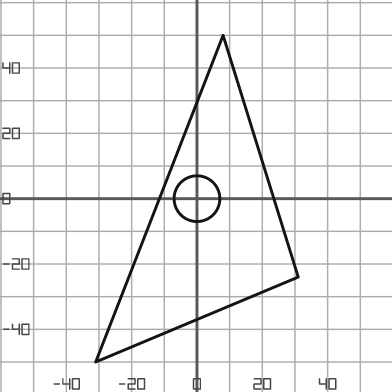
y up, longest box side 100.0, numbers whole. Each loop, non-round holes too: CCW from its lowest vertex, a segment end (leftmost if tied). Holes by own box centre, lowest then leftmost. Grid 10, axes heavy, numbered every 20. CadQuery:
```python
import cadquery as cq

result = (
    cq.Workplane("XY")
    .moveTo(-31.0, -50.0)
    .lineTo(31.0, -24.0)
    .lineTo(8.0, 50.0)
    .close()
    .moveTo(0.0, 0.0)
    .circle(7.0)
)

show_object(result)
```